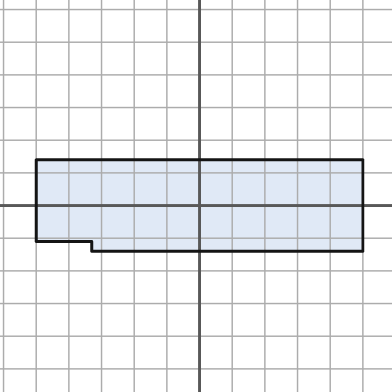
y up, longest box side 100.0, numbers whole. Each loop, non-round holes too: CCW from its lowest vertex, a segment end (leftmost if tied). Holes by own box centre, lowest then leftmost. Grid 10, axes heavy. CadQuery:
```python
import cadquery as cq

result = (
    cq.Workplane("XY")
    .moveTo(-33.0, -14.0)
    .lineTo(50.0, -14.0)
    .lineTo(50.0, 14.0)
    .lineTo(-50.0, 14.0)
    .lineTo(-50.0, -11.0)
    .lineTo(-33.0, -11.0)
    .close()
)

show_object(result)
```